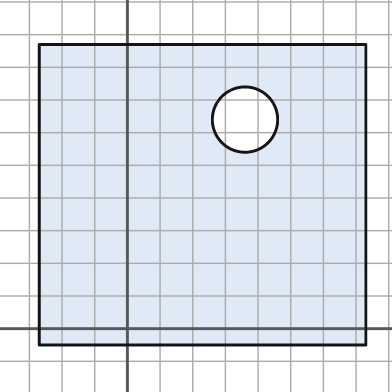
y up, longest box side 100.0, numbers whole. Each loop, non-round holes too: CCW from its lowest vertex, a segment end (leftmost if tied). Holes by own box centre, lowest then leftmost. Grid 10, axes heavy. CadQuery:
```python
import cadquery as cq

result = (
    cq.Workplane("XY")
    .moveTo(-27.0, -5.0)
    .lineTo(73.0, -5.0)
    .lineTo(73.0, 87.0)
    .lineTo(-27.0, 87.0)
    .close()
    .moveTo(36.0, 64.0)
    .circle(10.0)
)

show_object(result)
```